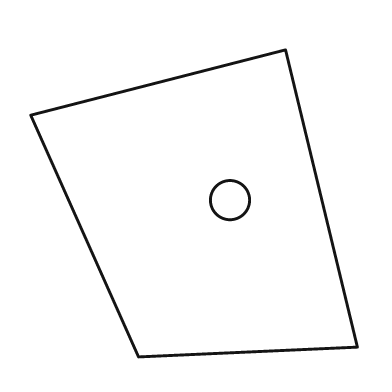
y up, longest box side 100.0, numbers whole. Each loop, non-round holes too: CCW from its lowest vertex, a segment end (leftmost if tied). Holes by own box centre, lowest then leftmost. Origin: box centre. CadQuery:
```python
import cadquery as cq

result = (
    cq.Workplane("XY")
    .moveTo(-17.0, -47.0)
    .lineTo(50.0, -44.0)
    .lineTo(28.0, 47.0)
    .lineTo(-50.0, 27.0)
    .close()
    .moveTo(11.0, 1.0)
    .circle(6.0)
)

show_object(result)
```